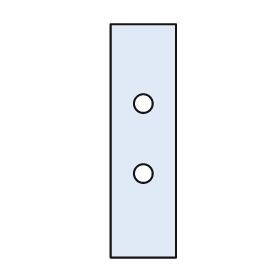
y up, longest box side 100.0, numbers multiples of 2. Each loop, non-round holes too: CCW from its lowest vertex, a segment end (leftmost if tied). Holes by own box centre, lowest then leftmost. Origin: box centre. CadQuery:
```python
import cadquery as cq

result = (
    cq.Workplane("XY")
    .moveTo(-14.0, -50.0)
    .lineTo(14.0, -50.0)
    .lineTo(14.0, 50.0)
    .lineTo(-14.0, 50.0)
    .close()
    .moveTo(0.0, -14.0)
    .circle(4.0)
    .moveTo(0.0, 16.0)
    .circle(4.0)
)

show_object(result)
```